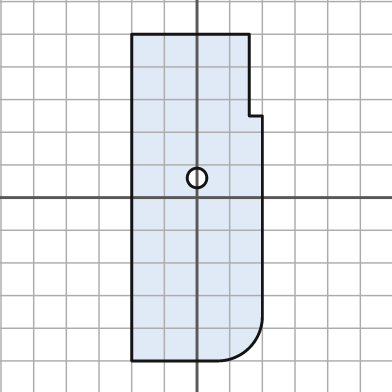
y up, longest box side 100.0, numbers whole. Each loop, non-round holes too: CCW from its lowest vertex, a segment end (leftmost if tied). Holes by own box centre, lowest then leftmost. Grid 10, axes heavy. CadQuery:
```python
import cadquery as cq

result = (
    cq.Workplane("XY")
    .moveTo(-20.0, -50.0)
    .lineTo(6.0, -50.0)
    .threePointArc((16.0, -46.0), (20.0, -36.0))
    .lineTo(20.0, 25.0)
    .lineTo(16.0, 25.0)
    .lineTo(16.0, 50.0)
    .lineTo(-20.0, 50.0)
    .close()
    .moveTo(0.0, 6.0)
    .circle(3.0)
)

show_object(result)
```